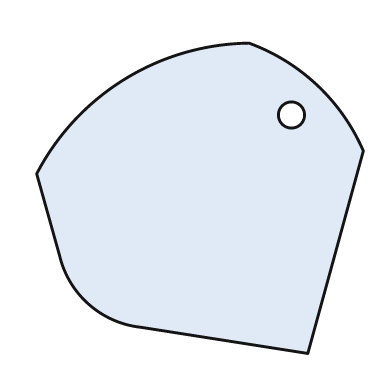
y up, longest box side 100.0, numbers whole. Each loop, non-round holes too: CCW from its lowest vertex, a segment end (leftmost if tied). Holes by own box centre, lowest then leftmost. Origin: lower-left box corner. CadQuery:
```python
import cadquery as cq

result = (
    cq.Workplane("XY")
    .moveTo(83.0, 0.0)
    .lineTo(100.0, 62.0)
    .threePointArc((86.0, 82.0), (65.0, 95.0))
    .threePointArc((27.0, 84.0), (0.0, 55.0))
    .lineTo(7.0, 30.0)
    .threePointArc((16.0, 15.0), (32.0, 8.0))
    .close()
    .moveTo(78.0, 73.0)
    .circle(4.0)
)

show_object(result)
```